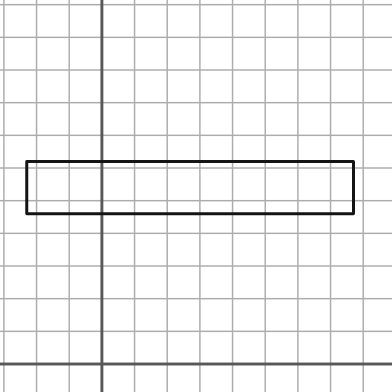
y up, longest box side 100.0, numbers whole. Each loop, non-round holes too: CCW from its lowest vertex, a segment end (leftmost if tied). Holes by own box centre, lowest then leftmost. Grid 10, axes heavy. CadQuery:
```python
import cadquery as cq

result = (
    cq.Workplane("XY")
    .moveTo(-23.0, 46.0)
    .lineTo(77.0, 46.0)
    .lineTo(77.0, 62.0)
    .lineTo(-23.0, 62.0)
    .close()
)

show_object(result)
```